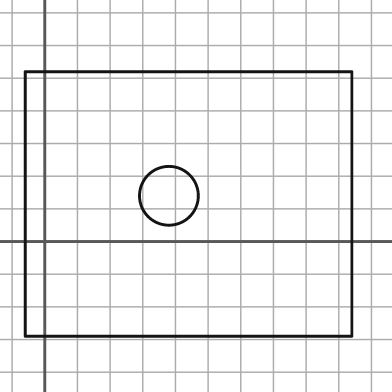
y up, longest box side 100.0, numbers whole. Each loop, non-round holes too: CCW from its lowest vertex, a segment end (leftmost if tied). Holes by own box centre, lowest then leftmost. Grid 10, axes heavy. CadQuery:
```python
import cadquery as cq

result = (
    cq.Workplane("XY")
    .moveTo(-6.0, -29.0)
    .lineTo(94.0, -29.0)
    .lineTo(94.0, 52.0)
    .lineTo(-6.0, 52.0)
    .close()
    .moveTo(38.0, 14.0)
    .circle(9.0)
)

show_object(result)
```